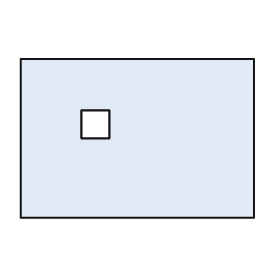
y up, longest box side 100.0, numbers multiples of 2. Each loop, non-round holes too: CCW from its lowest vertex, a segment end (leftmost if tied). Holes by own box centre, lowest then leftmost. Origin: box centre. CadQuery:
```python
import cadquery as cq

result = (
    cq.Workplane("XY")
    .moveTo(-50.0, -34.0)
    .lineTo(50.0, -34.0)
    .lineTo(50.0, 34.0)
    .lineTo(-50.0, 34.0)
    .close()
    .moveTo(-24.0, 0.0)
    .lineTo(-12.0, 0.0)
    .lineTo(-12.0, 12.0)
    .lineTo(-24.0, 12.0)
    .close()
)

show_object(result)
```